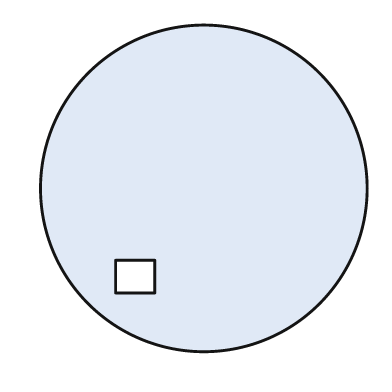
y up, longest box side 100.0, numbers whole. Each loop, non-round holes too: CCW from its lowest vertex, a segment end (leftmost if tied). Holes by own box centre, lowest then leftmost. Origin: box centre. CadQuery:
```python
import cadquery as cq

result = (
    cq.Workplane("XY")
    .moveTo(0.0, 0.0)
    .circle(50.0)
    .moveTo(-27.0, -32.0)
    .lineTo(-15.0, -32.0)
    .lineTo(-15.0, -22.0)
    .lineTo(-27.0, -22.0)
    .close()
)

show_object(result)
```